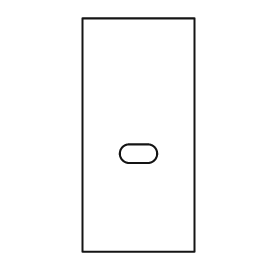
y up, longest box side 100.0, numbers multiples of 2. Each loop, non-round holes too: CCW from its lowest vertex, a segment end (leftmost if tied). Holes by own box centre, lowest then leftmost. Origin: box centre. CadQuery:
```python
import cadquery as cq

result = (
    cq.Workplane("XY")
    .moveTo(-24.0, -50.0)
    .lineTo(24.0, -50.0)
    .lineTo(24.0, 50.0)
    .lineTo(-24.0, 50.0)
    .close()
    .moveTo(-4.0, -12.0)
    .lineTo(4.0, -12.0)
    .threePointArc((8.0, -8.0), (4.0, -4.0))
    .lineTo(-4.0, -4.0)
    .threePointArc((-8.0, -8.0), (-4.0, -12.0))
    .close()
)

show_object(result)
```